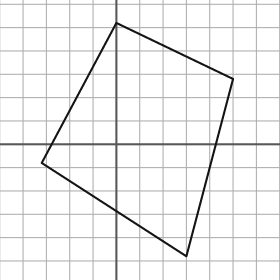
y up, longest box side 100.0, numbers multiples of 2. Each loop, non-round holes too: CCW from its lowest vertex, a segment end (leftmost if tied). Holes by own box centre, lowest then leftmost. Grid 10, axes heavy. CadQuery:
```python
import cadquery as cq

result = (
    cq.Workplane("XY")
    .moveTo(30.0, -48.0)
    .lineTo(50.0, 28.0)
    .lineTo(0.0, 52.0)
    .lineTo(-32.0, -8.0)
    .close()
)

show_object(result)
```